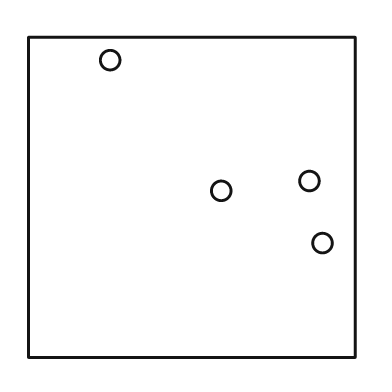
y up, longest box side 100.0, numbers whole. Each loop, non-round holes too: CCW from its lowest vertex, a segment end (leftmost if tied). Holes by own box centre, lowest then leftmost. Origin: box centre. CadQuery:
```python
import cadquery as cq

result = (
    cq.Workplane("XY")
    .moveTo(-50.0, -49.0)
    .lineTo(50.0, -49.0)
    .lineTo(50.0, 49.0)
    .lineTo(-50.0, 49.0)
    .close()
    .moveTo(40.0, -14.0)
    .circle(3.0)
    .moveTo(9.0, 2.0)
    .circle(3.0)
    .moveTo(36.0, 5.0)
    .circle(3.0)
    .moveTo(-25.0, 42.0)
    .circle(3.0)
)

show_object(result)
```